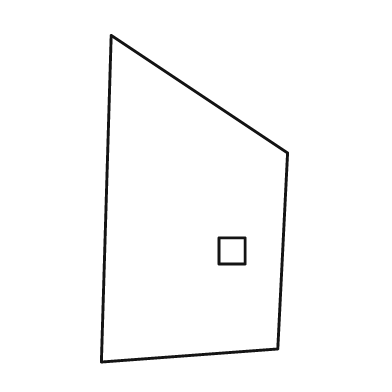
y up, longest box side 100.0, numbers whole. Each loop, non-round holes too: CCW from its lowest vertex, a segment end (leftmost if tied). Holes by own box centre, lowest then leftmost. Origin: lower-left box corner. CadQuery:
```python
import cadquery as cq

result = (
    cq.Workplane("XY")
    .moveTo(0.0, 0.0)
    .lineTo(54.0, 4.0)
    .lineTo(57.0, 64.0)
    .lineTo(3.0, 100.0)
    .close()
    .moveTo(36.0, 30.0)
    .lineTo(44.0, 30.0)
    .lineTo(44.0, 38.0)
    .lineTo(36.0, 38.0)
    .close()
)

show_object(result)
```